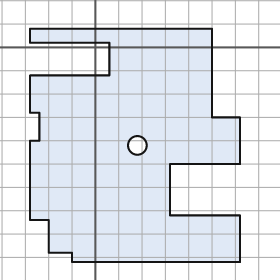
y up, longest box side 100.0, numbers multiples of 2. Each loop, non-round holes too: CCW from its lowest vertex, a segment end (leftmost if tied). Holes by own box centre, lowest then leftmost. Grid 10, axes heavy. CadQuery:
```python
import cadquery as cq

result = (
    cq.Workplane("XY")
    .moveTo(-10.0, -92.0)
    .lineTo(62.0, -92.0)
    .lineTo(62.0, -72.0)
    .lineTo(32.0, -72.0)
    .lineTo(32.0, -50.0)
    .lineTo(62.0, -50.0)
    .lineTo(62.0, -30.0)
    .lineTo(50.0, -30.0)
    .lineTo(50.0, 8.0)
    .lineTo(-28.0, 8.0)
    .lineTo(-28.0, 2.0)
    .lineTo(6.0, 2.0)
    .lineTo(6.0, -12.0)
    .lineTo(-28.0, -12.0)
    .lineTo(-28.0, -28.0)
    .lineTo(-24.0, -28.0)
    .lineTo(-24.0, -40.0)
    .lineTo(-28.0, -40.0)
    .lineTo(-28.0, -74.0)
    .lineTo(-20.0, -74.0)
    .lineTo(-20.0, -88.0)
    .lineTo(-10.0, -88.0)
    .close()
    .moveTo(18.0, -42.0)
    .circle(4.0)
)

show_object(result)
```